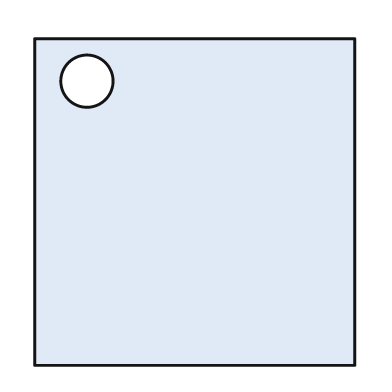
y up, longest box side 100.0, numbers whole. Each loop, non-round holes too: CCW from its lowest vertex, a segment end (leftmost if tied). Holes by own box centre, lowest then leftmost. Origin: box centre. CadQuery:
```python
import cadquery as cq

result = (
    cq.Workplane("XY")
    .moveTo(-49.0, -50.0)
    .lineTo(49.0, -50.0)
    .lineTo(49.0, 50.0)
    .lineTo(-49.0, 50.0)
    .close()
    .moveTo(-33.0, 37.0)
    .circle(8.0)
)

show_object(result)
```